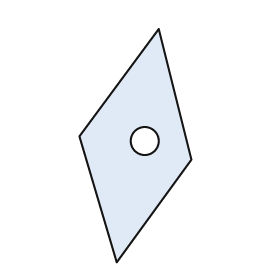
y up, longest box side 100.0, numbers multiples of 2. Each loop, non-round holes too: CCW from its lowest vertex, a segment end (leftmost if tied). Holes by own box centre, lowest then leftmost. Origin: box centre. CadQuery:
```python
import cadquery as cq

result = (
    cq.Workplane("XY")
    .moveTo(-8.0, -50.0)
    .lineTo(24.0, -6.0)
    .lineTo(10.0, 50.0)
    .lineTo(-24.0, 4.0)
    .close()
    .moveTo(4.0, 2.0)
    .circle(6.0)
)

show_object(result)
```